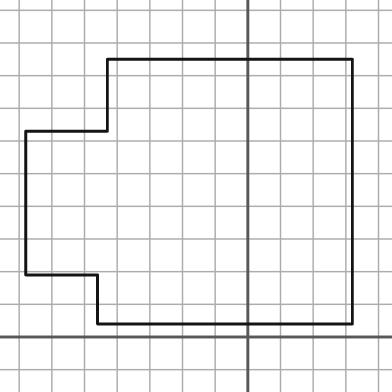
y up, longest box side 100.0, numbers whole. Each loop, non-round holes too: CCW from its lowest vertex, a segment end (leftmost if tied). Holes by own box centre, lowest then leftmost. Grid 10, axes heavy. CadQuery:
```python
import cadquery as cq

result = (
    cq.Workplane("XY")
    .moveTo(-46.0, 4.0)
    .lineTo(32.0, 4.0)
    .lineTo(32.0, 85.0)
    .lineTo(-43.0, 85.0)
    .lineTo(-43.0, 63.0)
    .lineTo(-68.0, 63.0)
    .lineTo(-68.0, 19.0)
    .lineTo(-46.0, 19.0)
    .close()
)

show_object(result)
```